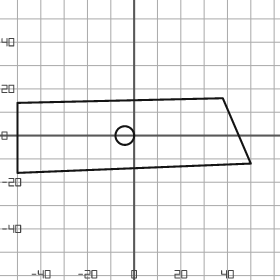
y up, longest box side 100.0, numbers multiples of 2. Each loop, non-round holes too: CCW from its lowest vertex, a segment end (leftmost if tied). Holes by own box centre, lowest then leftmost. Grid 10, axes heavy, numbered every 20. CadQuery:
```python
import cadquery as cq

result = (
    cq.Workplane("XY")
    .moveTo(-50.0, -16.0)
    .lineTo(50.0, -12.0)
    .lineTo(38.0, 16.0)
    .lineTo(-50.0, 14.0)
    .close()
    .moveTo(-4.0, 0.0)
    .circle(4.0)
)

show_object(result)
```